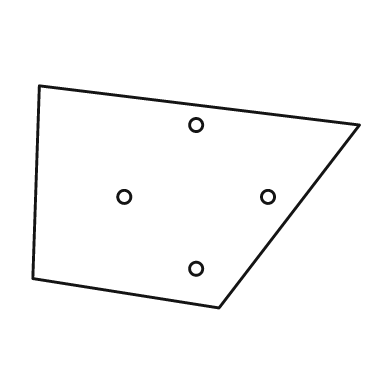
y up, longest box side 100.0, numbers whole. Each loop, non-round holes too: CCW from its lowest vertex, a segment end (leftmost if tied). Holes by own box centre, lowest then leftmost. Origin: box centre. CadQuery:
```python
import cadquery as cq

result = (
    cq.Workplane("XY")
    .moveTo(7.0, -34.0)
    .lineTo(50.0, 22.0)
    .lineTo(-48.0, 34.0)
    .lineTo(-50.0, -25.0)
    .close()
    .moveTo(0.0, -22.0)
    .circle(2.0)
    .moveTo(-22.0, 0.0)
    .circle(2.0)
    .moveTo(22.0, 0.0)
    .circle(2.0)
    .moveTo(0.0, 22.0)
    .circle(2.0)
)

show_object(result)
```